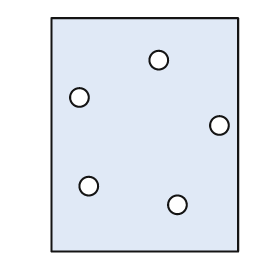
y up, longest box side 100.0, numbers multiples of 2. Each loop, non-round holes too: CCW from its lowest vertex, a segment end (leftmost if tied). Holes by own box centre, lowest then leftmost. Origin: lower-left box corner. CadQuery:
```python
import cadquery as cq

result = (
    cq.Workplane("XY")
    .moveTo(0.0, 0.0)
    .lineTo(80.0, 0.0)
    .lineTo(80.0, 100.0)
    .lineTo(0.0, 100.0)
    .close()
    .moveTo(54.0, 20.0)
    .circle(4.0)
    .moveTo(16.0, 28.0)
    .circle(4.0)
    .moveTo(72.0, 54.0)
    .circle(4.0)
    .moveTo(12.0, 66.0)
    .circle(4.0)
    .moveTo(46.0, 82.0)
    .circle(4.0)
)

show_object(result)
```